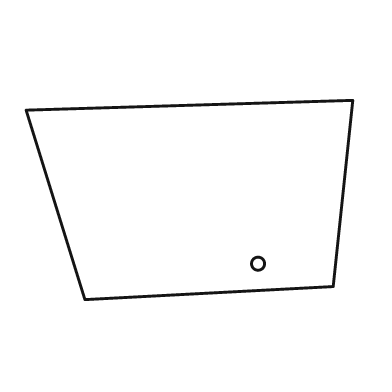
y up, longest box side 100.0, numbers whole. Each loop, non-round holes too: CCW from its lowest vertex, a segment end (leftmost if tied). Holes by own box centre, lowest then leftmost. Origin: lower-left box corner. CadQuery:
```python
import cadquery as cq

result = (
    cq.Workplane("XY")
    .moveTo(18.0, 0.0)
    .lineTo(94.0, 4.0)
    .lineTo(100.0, 61.0)
    .lineTo(0.0, 58.0)
    .close()
    .moveTo(71.0, 11.0)
    .circle(2.0)
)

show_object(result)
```